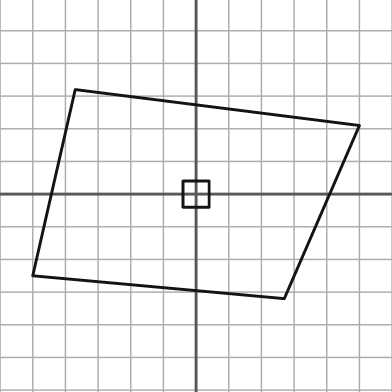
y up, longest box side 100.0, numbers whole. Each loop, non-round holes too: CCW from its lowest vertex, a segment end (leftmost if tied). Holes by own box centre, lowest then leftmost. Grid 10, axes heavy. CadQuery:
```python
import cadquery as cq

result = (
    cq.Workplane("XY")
    .moveTo(27.0, -32.0)
    .lineTo(50.0, 21.0)
    .lineTo(-37.0, 32.0)
    .lineTo(-50.0, -25.0)
    .close()
    .moveTo(-4.0, -4.0)
    .lineTo(4.0, -4.0)
    .lineTo(4.0, 4.0)
    .lineTo(-4.0, 4.0)
    .close()
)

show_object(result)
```